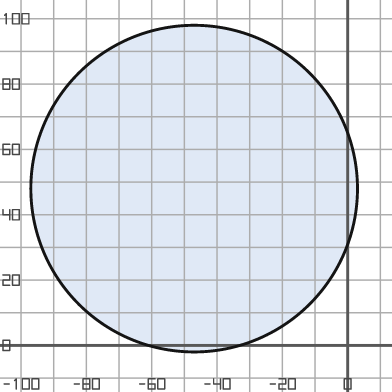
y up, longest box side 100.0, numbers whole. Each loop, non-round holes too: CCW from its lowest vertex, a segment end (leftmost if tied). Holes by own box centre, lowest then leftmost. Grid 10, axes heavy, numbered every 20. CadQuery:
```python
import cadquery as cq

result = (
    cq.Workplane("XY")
    .moveTo(-47.0, 48.0)
    .circle(50.0)
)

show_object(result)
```